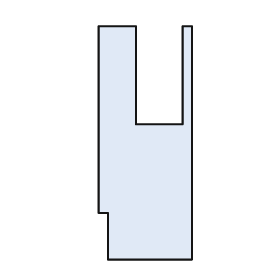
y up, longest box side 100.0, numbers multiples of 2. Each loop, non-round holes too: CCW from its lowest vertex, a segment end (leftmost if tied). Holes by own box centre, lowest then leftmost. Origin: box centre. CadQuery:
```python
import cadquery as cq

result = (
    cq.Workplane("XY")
    .moveTo(-16.0, -50.0)
    .lineTo(20.0, -50.0)
    .lineTo(20.0, 50.0)
    .lineTo(16.0, 50.0)
    .lineTo(16.0, 8.0)
    .lineTo(-4.0, 8.0)
    .lineTo(-4.0, 50.0)
    .lineTo(-20.0, 50.0)
    .lineTo(-20.0, -30.0)
    .lineTo(-16.0, -30.0)
    .close()
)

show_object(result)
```